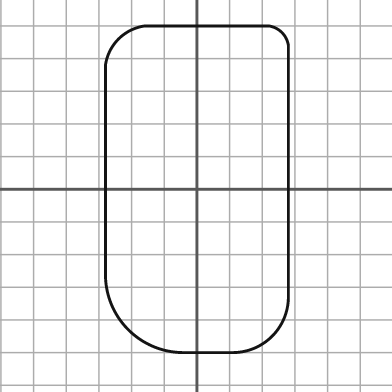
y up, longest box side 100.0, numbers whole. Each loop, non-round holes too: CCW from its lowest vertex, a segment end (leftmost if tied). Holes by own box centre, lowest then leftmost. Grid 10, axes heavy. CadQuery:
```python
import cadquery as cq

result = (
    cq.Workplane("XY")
    .moveTo(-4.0, -50.0)
    .lineTo(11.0, -50.0)
    .threePointArc((23.0, -45.0), (28.0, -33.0))
    .lineTo(28.0, 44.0)
    .threePointArc((26.0, 48.0), (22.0, 50.0))
    .lineTo(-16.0, 50.0)
    .threePointArc((-24.0, 46.0), (-28.0, 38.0))
    .lineTo(-28.0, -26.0)
    .threePointArc((-21.0, -43.0), (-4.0, -50.0))
    .close()
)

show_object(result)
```